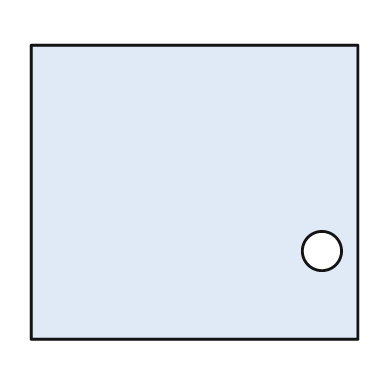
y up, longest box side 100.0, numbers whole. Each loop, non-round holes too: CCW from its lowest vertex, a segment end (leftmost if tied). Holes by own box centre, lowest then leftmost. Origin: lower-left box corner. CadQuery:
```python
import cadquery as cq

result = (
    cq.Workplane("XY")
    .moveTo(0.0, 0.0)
    .lineTo(100.0, 0.0)
    .lineTo(100.0, 90.0)
    .lineTo(0.0, 90.0)
    .close()
    .moveTo(89.0, 27.0)
    .circle(6.0)
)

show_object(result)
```